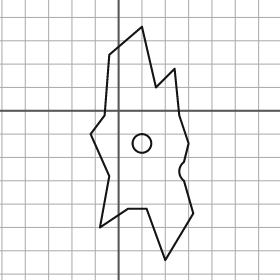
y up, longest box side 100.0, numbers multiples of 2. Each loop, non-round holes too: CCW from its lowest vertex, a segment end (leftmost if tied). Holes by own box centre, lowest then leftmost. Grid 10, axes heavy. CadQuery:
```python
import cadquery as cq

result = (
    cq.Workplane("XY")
    .moveTo(20.0, -64.0)
    .lineTo(32.0, -44.0)
    .lineTo(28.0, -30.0)
    .threePointArc((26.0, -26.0), (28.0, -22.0))
    .lineTo(30.0, -14.0)
    .lineTo(26.0, -2.0)
    .lineTo(24.0, 18.0)
    .lineTo(16.0, 10.0)
    .lineTo(10.0, 36.0)
    .lineTo(-4.0, 24.0)
    .lineTo(-6.0, -2.0)
    .lineTo(-12.0, -10.0)
    .lineTo(-4.0, -28.0)
    .lineTo(-8.0, -50.0)
    .lineTo(4.0, -42.0)
    .lineTo(12.0, -42.0)
    .close()
    .moveTo(10.0, -14.0)
    .circle(4.0)
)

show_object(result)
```